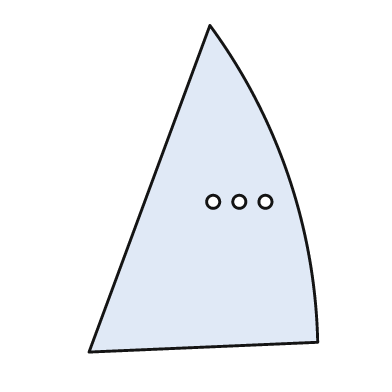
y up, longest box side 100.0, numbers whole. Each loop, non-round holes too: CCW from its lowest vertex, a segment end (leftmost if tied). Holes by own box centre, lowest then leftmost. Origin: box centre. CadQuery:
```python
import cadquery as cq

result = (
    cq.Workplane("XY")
    .moveTo(-35.0, -50.0)
    .lineTo(35.0, -47.0)
    .threePointArc((26.0, 4.0), (2.0, 50.0))
    .close()
    .moveTo(3.0, -4.0)
    .circle(2.0)
    .moveTo(11.0, -4.0)
    .circle(2.0)
    .moveTo(19.0, -4.0)
    .circle(2.0)
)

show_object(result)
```